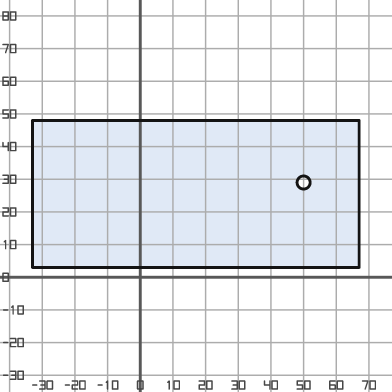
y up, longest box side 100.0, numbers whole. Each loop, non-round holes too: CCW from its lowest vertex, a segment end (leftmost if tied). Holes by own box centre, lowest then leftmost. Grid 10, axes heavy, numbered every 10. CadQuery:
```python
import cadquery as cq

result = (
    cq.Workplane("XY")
    .moveTo(-33.0, 3.0)
    .lineTo(67.0, 3.0)
    .lineTo(67.0, 48.0)
    .lineTo(-33.0, 48.0)
    .close()
    .moveTo(50.0, 29.0)
    .circle(2.0)
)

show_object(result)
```